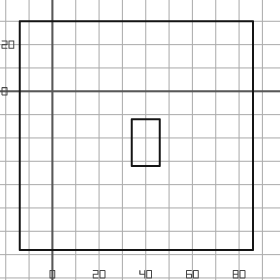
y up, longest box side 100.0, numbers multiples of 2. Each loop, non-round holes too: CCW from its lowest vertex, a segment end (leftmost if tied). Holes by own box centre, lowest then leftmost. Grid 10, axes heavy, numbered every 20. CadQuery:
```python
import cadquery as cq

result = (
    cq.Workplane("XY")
    .moveTo(-14.0, -68.0)
    .lineTo(86.0, -68.0)
    .lineTo(86.0, 30.0)
    .lineTo(-14.0, 30.0)
    .close()
    .moveTo(34.0, -32.0)
    .lineTo(46.0, -32.0)
    .lineTo(46.0, -12.0)
    .lineTo(34.0, -12.0)
    .close()
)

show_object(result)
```